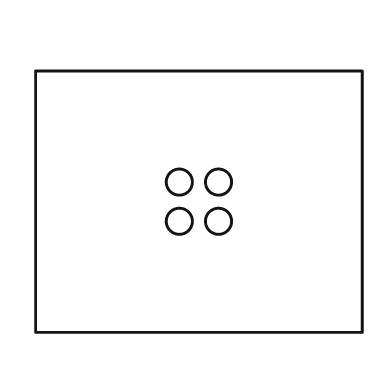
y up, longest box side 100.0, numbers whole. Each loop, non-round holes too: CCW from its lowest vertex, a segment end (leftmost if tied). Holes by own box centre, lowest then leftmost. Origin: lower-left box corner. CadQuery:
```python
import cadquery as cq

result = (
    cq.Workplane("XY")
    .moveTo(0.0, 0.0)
    .lineTo(100.0, 0.0)
    .lineTo(100.0, 80.0)
    .lineTo(0.0, 80.0)
    .close()
    .moveTo(44.0, 34.0)
    .circle(4.0)
    .moveTo(56.0, 34.0)
    .circle(4.0)
    .moveTo(44.0, 46.0)
    .circle(4.0)
    .moveTo(56.0, 46.0)
    .circle(4.0)
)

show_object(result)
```